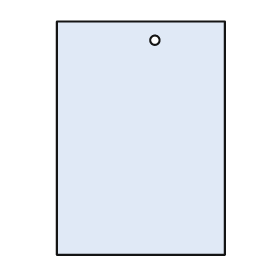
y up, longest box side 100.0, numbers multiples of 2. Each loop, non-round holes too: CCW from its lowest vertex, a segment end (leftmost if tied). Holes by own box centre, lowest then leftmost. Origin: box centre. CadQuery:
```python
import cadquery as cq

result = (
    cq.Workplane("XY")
    .moveTo(-36.0, -50.0)
    .lineTo(36.0, -50.0)
    .lineTo(36.0, 50.0)
    .lineTo(-36.0, 50.0)
    .close()
    .moveTo(6.0, 42.0)
    .circle(2.0)
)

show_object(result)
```